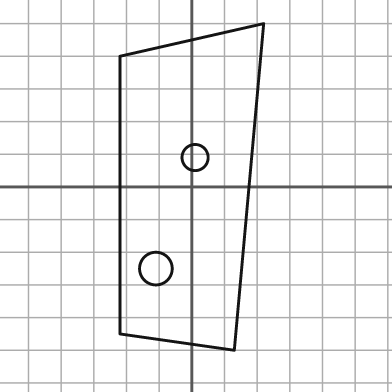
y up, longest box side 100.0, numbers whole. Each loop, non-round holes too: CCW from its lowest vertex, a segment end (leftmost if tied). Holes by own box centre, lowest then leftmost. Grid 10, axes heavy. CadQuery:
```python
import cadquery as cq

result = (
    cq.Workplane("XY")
    .moveTo(13.0, -50.0)
    .lineTo(22.0, 50.0)
    .lineTo(-22.0, 40.0)
    .lineTo(-22.0, -45.0)
    .close()
    .moveTo(-11.0, -25.0)
    .circle(5.0)
    .moveTo(1.0, 9.0)
    .circle(4.0)
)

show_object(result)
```